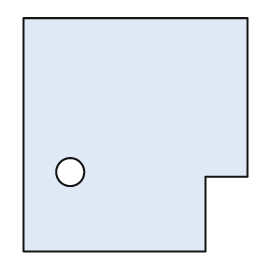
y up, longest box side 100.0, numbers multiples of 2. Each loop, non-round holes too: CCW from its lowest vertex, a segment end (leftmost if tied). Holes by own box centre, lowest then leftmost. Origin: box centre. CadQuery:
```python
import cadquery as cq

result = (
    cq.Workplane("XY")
    .moveTo(-48.0, -50.0)
    .lineTo(30.0, -50.0)
    .lineTo(30.0, -18.0)
    .lineTo(48.0, -18.0)
    .lineTo(48.0, 50.0)
    .lineTo(-48.0, 50.0)
    .close()
    .moveTo(-28.0, -16.0)
    .circle(6.0)
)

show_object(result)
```